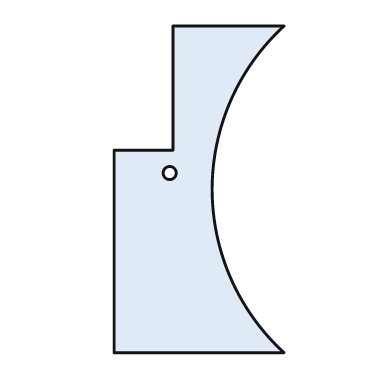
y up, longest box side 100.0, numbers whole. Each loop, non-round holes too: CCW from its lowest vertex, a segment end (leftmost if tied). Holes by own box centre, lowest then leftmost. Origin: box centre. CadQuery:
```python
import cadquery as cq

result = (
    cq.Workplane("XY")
    .moveTo(-26.0, -50.0)
    .lineTo(26.0, -50.0)
    .threePointArc((4.0, 0.0), (26.0, 50.0))
    .lineTo(-8.0, 50.0)
    .lineTo(-8.0, 12.0)
    .lineTo(-26.0, 12.0)
    .close()
    .moveTo(-9.0, 5.0)
    .circle(2.0)
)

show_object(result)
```